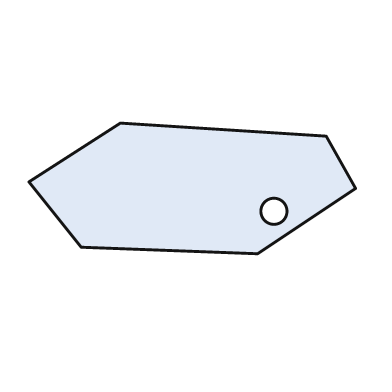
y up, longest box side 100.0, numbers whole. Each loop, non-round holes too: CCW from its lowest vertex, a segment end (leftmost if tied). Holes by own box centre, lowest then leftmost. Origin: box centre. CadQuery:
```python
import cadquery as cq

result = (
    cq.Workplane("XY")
    .moveTo(20.0, -20.0)
    .lineTo(50.0, 0.0)
    .lineTo(41.0, 16.0)
    .lineTo(-22.0, 20.0)
    .lineTo(-50.0, 2.0)
    .lineTo(-34.0, -18.0)
    .close()
    .moveTo(25.0, -7.0)
    .circle(4.0)
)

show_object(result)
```